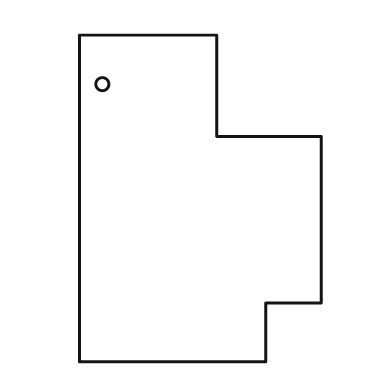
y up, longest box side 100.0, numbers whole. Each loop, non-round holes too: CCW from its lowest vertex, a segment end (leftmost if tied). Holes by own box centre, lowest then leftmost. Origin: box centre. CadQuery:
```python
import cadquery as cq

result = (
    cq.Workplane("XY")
    .moveTo(-37.0, -50.0)
    .lineTo(20.0, -50.0)
    .lineTo(20.0, -32.0)
    .lineTo(37.0, -32.0)
    .lineTo(37.0, 19.0)
    .lineTo(5.0, 19.0)
    .lineTo(5.0, 50.0)
    .lineTo(-37.0, 50.0)
    .close()
    .moveTo(-30.0, 35.0)
    .circle(2.0)
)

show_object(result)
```